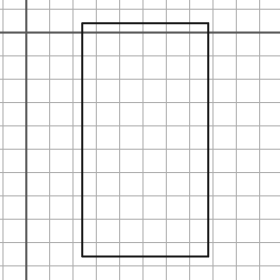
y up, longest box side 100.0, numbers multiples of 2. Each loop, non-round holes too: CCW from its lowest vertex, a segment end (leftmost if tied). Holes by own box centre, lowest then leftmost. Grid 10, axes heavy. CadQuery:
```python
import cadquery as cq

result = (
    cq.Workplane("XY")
    .moveTo(24.0, -96.0)
    .lineTo(78.0, -96.0)
    .lineTo(78.0, 4.0)
    .lineTo(24.0, 4.0)
    .close()
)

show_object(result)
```